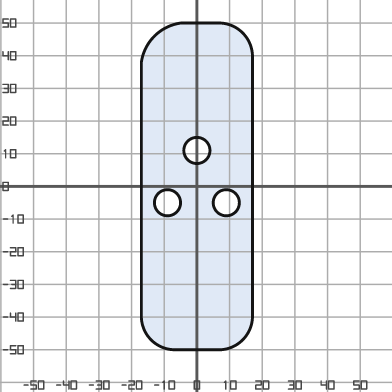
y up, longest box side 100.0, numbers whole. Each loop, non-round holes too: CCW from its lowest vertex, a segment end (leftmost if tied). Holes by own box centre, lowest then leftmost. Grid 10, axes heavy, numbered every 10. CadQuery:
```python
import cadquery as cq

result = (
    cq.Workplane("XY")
    .moveTo(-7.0, -50.0)
    .lineTo(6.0, -50.0)
    .threePointArc((14.0, -47.0), (17.0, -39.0))
    .lineTo(17.0, 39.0)
    .threePointArc((14.0, 47.0), (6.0, 50.0))
    .lineTo(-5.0, 50.0)
    .threePointArc((-13.0, 46.0), (-17.0, 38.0))
    .lineTo(-17.0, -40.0)
    .threePointArc((-14.0, -47.0), (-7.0, -50.0))
    .close()
    .moveTo(-9.0, -5.0)
    .circle(4.0)
    .moveTo(9.0, -5.0)
    .circle(4.0)
    .moveTo(0.0, 11.0)
    .circle(4.0)
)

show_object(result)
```